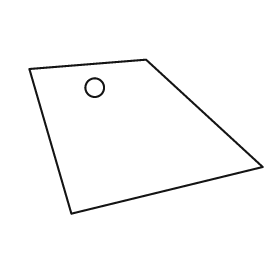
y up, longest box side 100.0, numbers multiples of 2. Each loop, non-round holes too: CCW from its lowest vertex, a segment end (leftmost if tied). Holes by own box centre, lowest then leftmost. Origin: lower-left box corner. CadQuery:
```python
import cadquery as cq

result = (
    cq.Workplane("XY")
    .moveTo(18.0, 0.0)
    .lineTo(100.0, 20.0)
    .lineTo(50.0, 66.0)
    .lineTo(0.0, 62.0)
    .close()
    .moveTo(28.0, 54.0)
    .circle(4.0)
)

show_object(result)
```